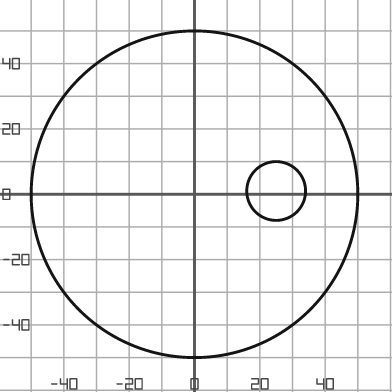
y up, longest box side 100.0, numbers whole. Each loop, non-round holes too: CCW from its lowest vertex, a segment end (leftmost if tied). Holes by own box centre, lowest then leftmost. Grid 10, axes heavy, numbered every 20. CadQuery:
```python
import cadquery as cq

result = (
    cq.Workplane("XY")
    .moveTo(0.0, 0.0)
    .circle(50.0)
    .moveTo(25.0, 1.0)
    .circle(9.0)
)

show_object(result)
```